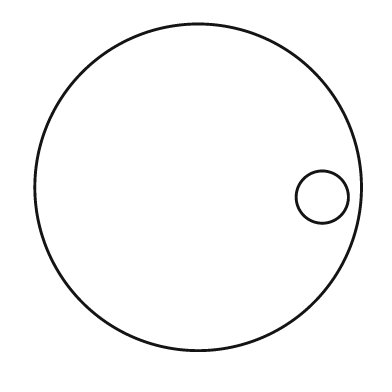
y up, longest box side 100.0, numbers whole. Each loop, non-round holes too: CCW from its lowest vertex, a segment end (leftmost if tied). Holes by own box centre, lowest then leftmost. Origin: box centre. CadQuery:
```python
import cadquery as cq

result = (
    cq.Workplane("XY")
    .moveTo(0.0, 0.0)
    .circle(50.0)
    .moveTo(38.0, -3.0)
    .circle(8.0)
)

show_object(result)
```